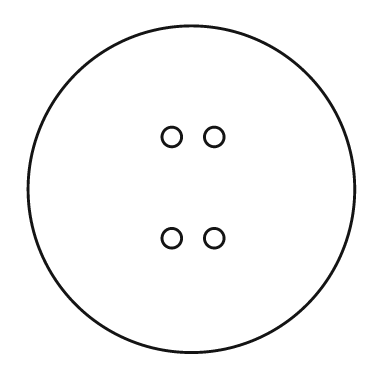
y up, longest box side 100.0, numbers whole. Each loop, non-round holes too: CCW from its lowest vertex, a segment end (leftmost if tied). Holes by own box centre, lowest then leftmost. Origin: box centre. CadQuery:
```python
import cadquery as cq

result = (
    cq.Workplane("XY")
    .moveTo(0.0, 0.0)
    .circle(50.0)
    .moveTo(-6.0, -15.0)
    .circle(3.0)
    .moveTo(7.0, -15.0)
    .circle(3.0)
    .moveTo(-6.0, 16.0)
    .circle(3.0)
    .moveTo(7.0, 16.0)
    .circle(3.0)
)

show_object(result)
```